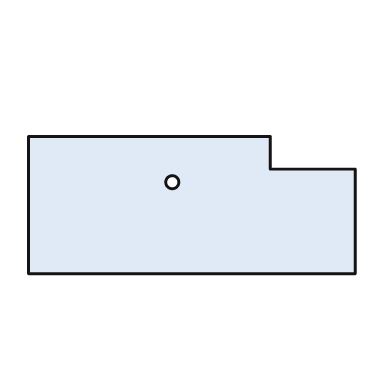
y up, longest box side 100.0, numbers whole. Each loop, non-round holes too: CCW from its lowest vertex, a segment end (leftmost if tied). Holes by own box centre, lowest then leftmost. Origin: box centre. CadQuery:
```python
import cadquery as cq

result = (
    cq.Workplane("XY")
    .moveTo(-50.0, -21.0)
    .lineTo(50.0, -21.0)
    .lineTo(50.0, 11.0)
    .lineTo(24.0, 11.0)
    .lineTo(24.0, 21.0)
    .lineTo(-50.0, 21.0)
    .close()
    .moveTo(-6.0, 7.0)
    .circle(2.0)
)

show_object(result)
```